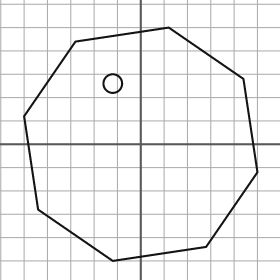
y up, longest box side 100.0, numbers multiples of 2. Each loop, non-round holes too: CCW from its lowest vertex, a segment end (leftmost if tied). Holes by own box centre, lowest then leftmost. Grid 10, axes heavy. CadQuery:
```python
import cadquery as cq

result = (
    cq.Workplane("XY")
    .moveTo(-12.0, -50.0)
    .lineTo(28.0, -44.0)
    .lineTo(50.0, -12.0)
    .lineTo(44.0, 28.0)
    .lineTo(12.0, 50.0)
    .lineTo(-28.0, 44.0)
    .lineTo(-50.0, 12.0)
    .lineTo(-44.0, -28.0)
    .close()
    .moveTo(-12.0, 26.0)
    .circle(4.0)
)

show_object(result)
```